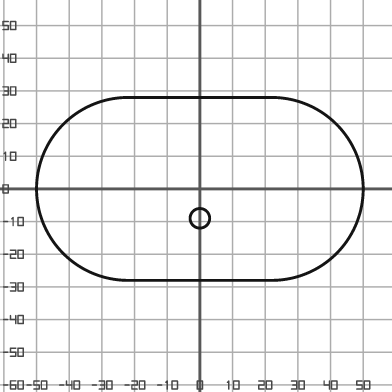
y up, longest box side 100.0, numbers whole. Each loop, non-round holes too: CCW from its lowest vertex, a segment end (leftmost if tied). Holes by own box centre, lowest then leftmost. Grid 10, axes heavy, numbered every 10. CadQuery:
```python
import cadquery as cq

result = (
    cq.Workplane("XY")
    .moveTo(-22.0, -28.0)
    .lineTo(22.0, -28.0)
    .threePointArc((50.0, 0.0), (22.0, 28.0))
    .lineTo(-22.0, 28.0)
    .threePointArc((-50.0, 0.0), (-22.0, -28.0))
    .close()
    .moveTo(0.0, -9.0)
    .circle(3.0)
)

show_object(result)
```